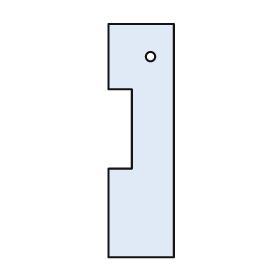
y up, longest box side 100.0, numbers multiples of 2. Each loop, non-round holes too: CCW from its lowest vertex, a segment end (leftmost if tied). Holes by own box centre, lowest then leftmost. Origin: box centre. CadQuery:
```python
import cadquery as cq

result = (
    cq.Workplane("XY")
    .moveTo(-14.0, -50.0)
    .lineTo(14.0, -50.0)
    .lineTo(14.0, 50.0)
    .lineTo(-14.0, 50.0)
    .lineTo(-14.0, 22.0)
    .lineTo(-4.0, 22.0)
    .lineTo(-4.0, -12.0)
    .lineTo(-14.0, -12.0)
    .close()
    .moveTo(4.0, 36.0)
    .circle(2.0)
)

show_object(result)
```